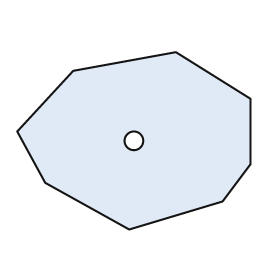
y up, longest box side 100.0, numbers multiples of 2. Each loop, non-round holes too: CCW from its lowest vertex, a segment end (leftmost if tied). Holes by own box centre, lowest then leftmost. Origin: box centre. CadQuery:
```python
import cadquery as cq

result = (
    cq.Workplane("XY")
    .moveTo(-2.0, -38.0)
    .lineTo(38.0, -26.0)
    .lineTo(50.0, -10.0)
    .lineTo(50.0, 18.0)
    .lineTo(18.0, 38.0)
    .lineTo(-26.0, 30.0)
    .lineTo(-50.0, 4.0)
    .lineTo(-38.0, -18.0)
    .close()
    .moveTo(0.0, 0.0)
    .circle(4.0)
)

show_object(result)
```